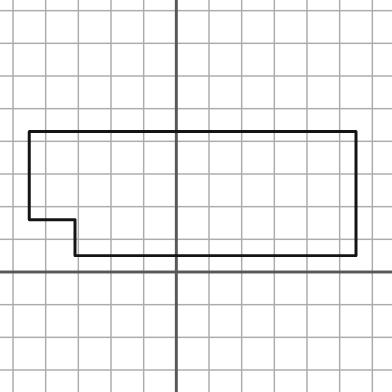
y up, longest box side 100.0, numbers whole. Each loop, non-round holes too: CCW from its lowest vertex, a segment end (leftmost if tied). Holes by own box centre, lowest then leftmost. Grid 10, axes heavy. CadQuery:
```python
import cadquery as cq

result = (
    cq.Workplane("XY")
    .moveTo(-31.0, 5.0)
    .lineTo(55.0, 5.0)
    .lineTo(55.0, 43.0)
    .lineTo(-45.0, 43.0)
    .lineTo(-45.0, 16.0)
    .lineTo(-31.0, 16.0)
    .close()
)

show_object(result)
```